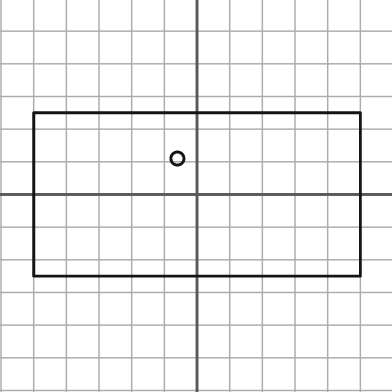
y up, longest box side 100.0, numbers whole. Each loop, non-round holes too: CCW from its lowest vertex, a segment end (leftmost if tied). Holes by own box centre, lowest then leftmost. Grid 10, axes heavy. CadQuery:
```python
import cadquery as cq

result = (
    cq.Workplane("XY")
    .moveTo(-50.0, -25.0)
    .lineTo(50.0, -25.0)
    .lineTo(50.0, 25.0)
    .lineTo(-50.0, 25.0)
    .close()
    .moveTo(-6.0, 11.0)
    .circle(2.0)
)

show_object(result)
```